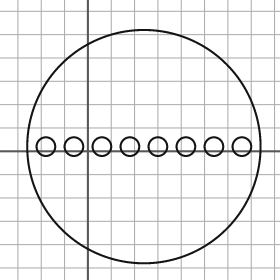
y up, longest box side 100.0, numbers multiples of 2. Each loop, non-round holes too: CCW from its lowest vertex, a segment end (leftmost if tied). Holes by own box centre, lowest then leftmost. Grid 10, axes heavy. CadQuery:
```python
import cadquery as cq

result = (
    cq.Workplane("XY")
    .moveTo(24.0, 2.0)
    .circle(50.0)
    .moveTo(-18.0, 2.0)
    .circle(4.0)
    .moveTo(-6.0, 2.0)
    .circle(4.0)
    .moveTo(6.0, 2.0)
    .circle(4.0)
    .moveTo(18.0, 2.0)
    .circle(4.0)
    .moveTo(30.0, 2.0)
    .circle(4.0)
    .moveTo(42.0, 2.0)
    .circle(4.0)
    .moveTo(54.0, 2.0)
    .circle(4.0)
    .moveTo(66.0, 2.0)
    .circle(4.0)
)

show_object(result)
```